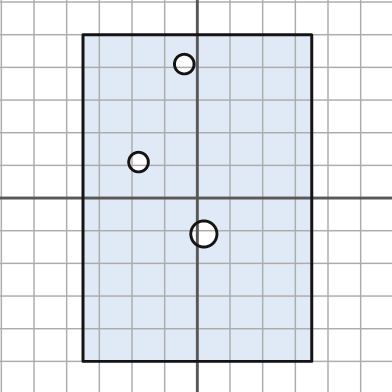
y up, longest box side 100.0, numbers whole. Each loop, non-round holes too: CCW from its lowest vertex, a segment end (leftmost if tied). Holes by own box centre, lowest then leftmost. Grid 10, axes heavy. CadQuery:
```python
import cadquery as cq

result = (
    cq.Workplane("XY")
    .moveTo(-35.0, -50.0)
    .lineTo(35.0, -50.0)
    .lineTo(35.0, 50.0)
    .lineTo(-35.0, 50.0)
    .close()
    .moveTo(2.0, -11.0)
    .circle(4.0)
    .moveTo(-18.0, 11.0)
    .circle(3.0)
    .moveTo(-4.0, 41.0)
    .circle(3.0)
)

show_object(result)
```